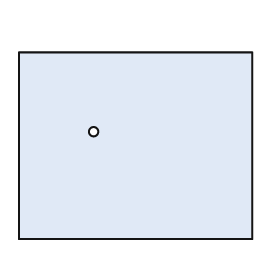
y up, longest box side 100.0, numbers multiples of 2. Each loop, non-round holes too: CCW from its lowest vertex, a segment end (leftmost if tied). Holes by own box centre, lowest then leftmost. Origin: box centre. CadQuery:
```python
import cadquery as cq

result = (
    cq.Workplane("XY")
    .moveTo(-50.0, -40.0)
    .lineTo(50.0, -40.0)
    .lineTo(50.0, 40.0)
    .lineTo(-50.0, 40.0)
    .close()
    .moveTo(-18.0, 6.0)
    .circle(2.0)
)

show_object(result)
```